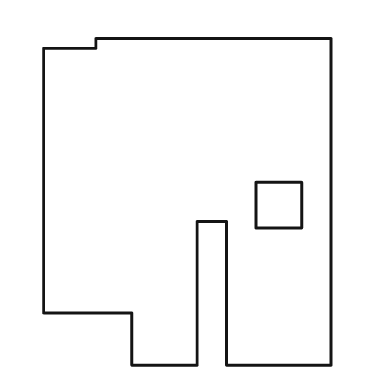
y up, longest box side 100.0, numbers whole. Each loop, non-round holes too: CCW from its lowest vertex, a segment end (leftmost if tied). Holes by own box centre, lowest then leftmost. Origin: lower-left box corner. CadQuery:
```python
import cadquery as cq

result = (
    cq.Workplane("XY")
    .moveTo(27.0, 0.0)
    .lineTo(47.0, 0.0)
    .lineTo(47.0, 44.0)
    .lineTo(56.0, 44.0)
    .lineTo(56.0, 0.0)
    .lineTo(88.0, 0.0)
    .lineTo(88.0, 100.0)
    .lineTo(16.0, 100.0)
    .lineTo(16.0, 97.0)
    .lineTo(0.0, 97.0)
    .lineTo(0.0, 16.0)
    .lineTo(27.0, 16.0)
    .close()
    .moveTo(65.0, 42.0)
    .lineTo(79.0, 42.0)
    .lineTo(79.0, 56.0)
    .lineTo(65.0, 56.0)
    .close()
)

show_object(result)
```